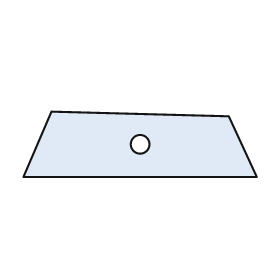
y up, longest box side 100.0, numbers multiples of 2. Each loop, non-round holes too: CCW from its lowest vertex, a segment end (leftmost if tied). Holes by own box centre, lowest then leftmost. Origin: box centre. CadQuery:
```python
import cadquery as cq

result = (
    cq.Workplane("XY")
    .moveTo(-50.0, -14.0)
    .lineTo(50.0, -14.0)
    .lineTo(38.0, 12.0)
    .lineTo(-38.0, 14.0)
    .close()
    .moveTo(0.0, 0.0)
    .circle(4.0)
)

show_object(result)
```